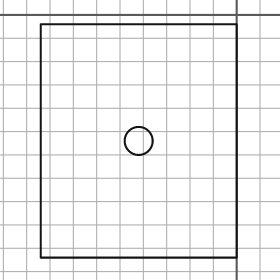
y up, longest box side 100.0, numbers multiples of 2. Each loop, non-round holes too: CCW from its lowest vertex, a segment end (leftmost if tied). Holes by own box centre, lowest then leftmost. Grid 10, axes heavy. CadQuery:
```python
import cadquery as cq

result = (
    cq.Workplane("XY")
    .moveTo(-84.0, -104.0)
    .lineTo(0.0, -104.0)
    .lineTo(0.0, -4.0)
    .lineTo(-84.0, -4.0)
    .close()
    .moveTo(-42.0, -54.0)
    .circle(6.0)
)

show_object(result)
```